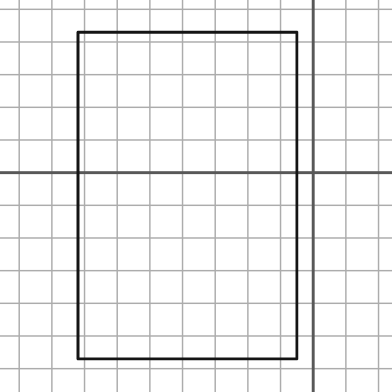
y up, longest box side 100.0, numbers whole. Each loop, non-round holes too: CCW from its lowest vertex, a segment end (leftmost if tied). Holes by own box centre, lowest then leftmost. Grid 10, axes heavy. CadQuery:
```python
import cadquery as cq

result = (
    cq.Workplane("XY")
    .moveTo(-72.0, -57.0)
    .lineTo(-5.0, -57.0)
    .lineTo(-5.0, 43.0)
    .lineTo(-72.0, 43.0)
    .close()
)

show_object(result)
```